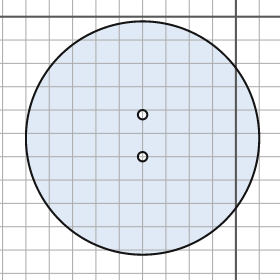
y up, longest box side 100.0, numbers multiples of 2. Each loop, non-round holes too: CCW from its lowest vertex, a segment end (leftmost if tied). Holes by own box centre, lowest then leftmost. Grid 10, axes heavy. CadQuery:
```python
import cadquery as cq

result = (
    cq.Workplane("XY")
    .moveTo(-40.0, -52.0)
    .circle(50.0)
    .moveTo(-40.0, -60.0)
    .circle(2.0)
    .moveTo(-40.0, -42.0)
    .circle(2.0)
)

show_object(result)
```